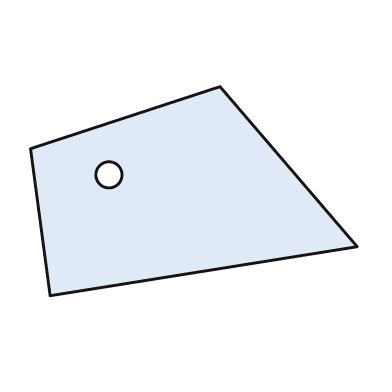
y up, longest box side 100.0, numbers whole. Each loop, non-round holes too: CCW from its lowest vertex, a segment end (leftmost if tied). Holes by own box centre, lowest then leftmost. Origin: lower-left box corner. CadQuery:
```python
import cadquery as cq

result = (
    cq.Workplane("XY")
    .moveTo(6.0, 0.0)
    .lineTo(100.0, 15.0)
    .lineTo(58.0, 64.0)
    .lineTo(0.0, 45.0)
    .close()
    .moveTo(24.0, 37.0)
    .circle(4.0)
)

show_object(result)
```